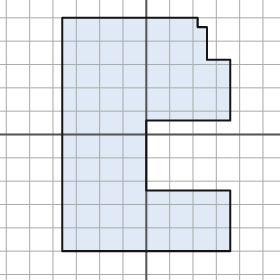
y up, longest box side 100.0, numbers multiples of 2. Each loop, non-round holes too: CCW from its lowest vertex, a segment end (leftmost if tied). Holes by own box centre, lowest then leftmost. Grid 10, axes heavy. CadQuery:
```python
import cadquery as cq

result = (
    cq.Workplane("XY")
    .moveTo(-36.0, -50.0)
    .lineTo(36.0, -50.0)
    .lineTo(36.0, -24.0)
    .lineTo(0.0, -24.0)
    .lineTo(0.0, 6.0)
    .lineTo(36.0, 6.0)
    .lineTo(36.0, 32.0)
    .lineTo(26.0, 32.0)
    .lineTo(26.0, 46.0)
    .lineTo(22.0, 46.0)
    .lineTo(22.0, 50.0)
    .lineTo(-36.0, 50.0)
    .close()
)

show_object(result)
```